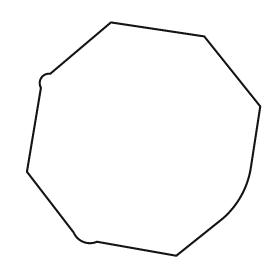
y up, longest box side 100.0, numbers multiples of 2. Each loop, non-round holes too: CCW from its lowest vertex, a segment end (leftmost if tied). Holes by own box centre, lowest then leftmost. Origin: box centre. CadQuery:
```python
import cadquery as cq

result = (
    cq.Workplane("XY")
    .moveTo(14.0, -50.0)
    .lineTo(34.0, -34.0)
    .threePointArc((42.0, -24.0), (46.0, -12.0))
    .lineTo(50.0, 14.0)
    .lineTo(26.0, 44.0)
    .lineTo(-14.0, 50.0)
    .lineTo(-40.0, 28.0)
    .threePointArc((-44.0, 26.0), (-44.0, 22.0))
    .lineTo(-50.0, -14.0)
    .lineTo(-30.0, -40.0)
    .threePointArc((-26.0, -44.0), (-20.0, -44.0))
    .close()
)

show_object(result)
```